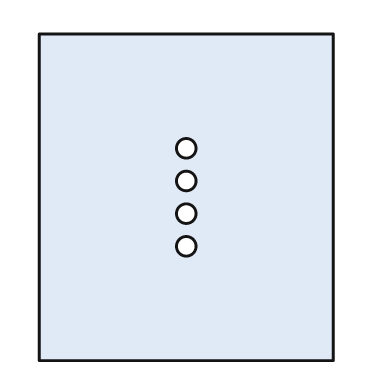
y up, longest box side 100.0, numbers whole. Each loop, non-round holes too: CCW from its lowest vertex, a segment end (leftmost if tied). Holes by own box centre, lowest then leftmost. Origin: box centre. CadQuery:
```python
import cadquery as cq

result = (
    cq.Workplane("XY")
    .moveTo(-45.0, -50.0)
    .lineTo(45.0, -50.0)
    .lineTo(45.0, 50.0)
    .lineTo(-45.0, 50.0)
    .close()
    .moveTo(0.0, -15.0)
    .circle(3.0)
    .moveTo(0.0, -5.0)
    .circle(3.0)
    .moveTo(0.0, 5.0)
    .circle(3.0)
    .moveTo(0.0, 15.0)
    .circle(3.0)
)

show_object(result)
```